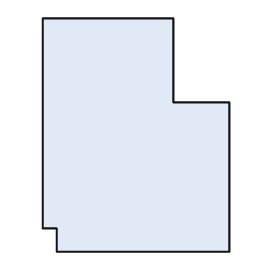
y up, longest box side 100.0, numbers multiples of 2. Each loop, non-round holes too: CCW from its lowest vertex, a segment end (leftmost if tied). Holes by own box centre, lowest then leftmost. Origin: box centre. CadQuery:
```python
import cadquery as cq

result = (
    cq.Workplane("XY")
    .moveTo(-34.0, -50.0)
    .lineTo(40.0, -50.0)
    .lineTo(40.0, 14.0)
    .lineTo(16.0, 14.0)
    .lineTo(16.0, 50.0)
    .lineTo(-40.0, 50.0)
    .lineTo(-40.0, -40.0)
    .lineTo(-34.0, -40.0)
    .close()
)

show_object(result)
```